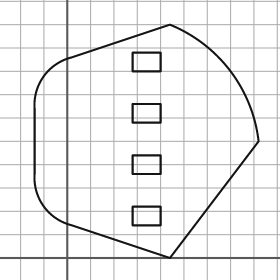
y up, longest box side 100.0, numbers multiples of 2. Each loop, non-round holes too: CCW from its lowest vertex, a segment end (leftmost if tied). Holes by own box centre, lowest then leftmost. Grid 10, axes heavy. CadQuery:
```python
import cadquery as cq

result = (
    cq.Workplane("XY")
    .moveTo(44.0, 0.0)
    .lineTo(82.0, 50.0)
    .threePointArc((70.0, 80.0), (44.0, 100.0))
    .lineTo(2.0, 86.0)
    .threePointArc((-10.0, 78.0), (-14.0, 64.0))
    .lineTo(-14.0, 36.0)
    .threePointArc((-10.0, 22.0), (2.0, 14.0))
    .close()
    .moveTo(28.0, 14.0)
    .lineTo(40.0, 14.0)
    .lineTo(40.0, 22.0)
    .lineTo(28.0, 22.0)
    .close()
    .moveTo(28.0, 36.0)
    .lineTo(40.0, 36.0)
    .lineTo(40.0, 44.0)
    .lineTo(28.0, 44.0)
    .close()
    .moveTo(28.0, 58.0)
    .lineTo(40.0, 58.0)
    .lineTo(40.0, 66.0)
    .lineTo(28.0, 66.0)
    .close()
    .moveTo(28.0, 80.0)
    .lineTo(40.0, 80.0)
    .lineTo(40.0, 88.0)
    .lineTo(28.0, 88.0)
    .close()
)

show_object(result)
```